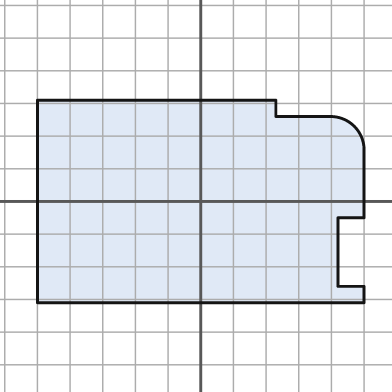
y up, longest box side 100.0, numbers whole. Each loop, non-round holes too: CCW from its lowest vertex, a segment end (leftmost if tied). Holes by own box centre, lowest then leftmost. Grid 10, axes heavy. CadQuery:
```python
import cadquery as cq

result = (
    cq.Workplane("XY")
    .moveTo(-50.0, -31.0)
    .lineTo(50.0, -31.0)
    .lineTo(50.0, -26.0)
    .lineTo(42.0, -26.0)
    .lineTo(42.0, -5.0)
    .lineTo(50.0, -5.0)
    .lineTo(50.0, 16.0)
    .threePointArc((47.0, 23.0), (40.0, 26.0))
    .lineTo(23.0, 26.0)
    .lineTo(23.0, 31.0)
    .lineTo(-50.0, 31.0)
    .close()
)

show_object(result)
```